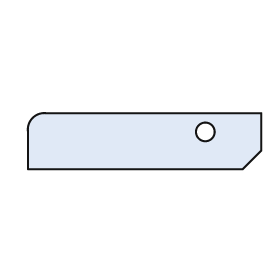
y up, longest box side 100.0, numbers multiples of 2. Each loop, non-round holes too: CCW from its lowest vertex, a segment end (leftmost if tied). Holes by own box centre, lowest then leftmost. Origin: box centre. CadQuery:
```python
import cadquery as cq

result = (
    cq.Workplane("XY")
    .moveTo(-50.0, -12.0)
    .lineTo(42.0, -12.0)
    .lineTo(50.0, -4.0)
    .lineTo(50.0, 12.0)
    .lineTo(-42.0, 12.0)
    .threePointArc((-48.0, 10.0), (-50.0, 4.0))
    .close()
    .moveTo(26.0, 4.0)
    .circle(4.0)
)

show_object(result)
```